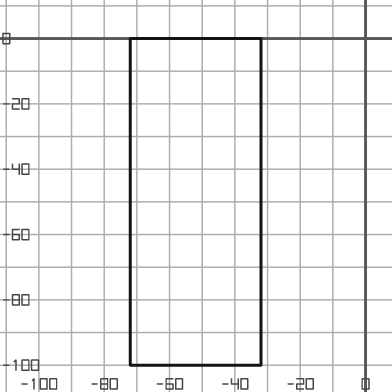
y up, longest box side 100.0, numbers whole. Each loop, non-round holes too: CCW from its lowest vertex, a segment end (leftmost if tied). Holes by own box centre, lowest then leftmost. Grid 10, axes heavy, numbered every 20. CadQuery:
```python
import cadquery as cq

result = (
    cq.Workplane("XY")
    .moveTo(-72.0, -100.0)
    .lineTo(-32.0, -100.0)
    .lineTo(-32.0, 0.0)
    .lineTo(-72.0, 0.0)
    .close()
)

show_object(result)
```